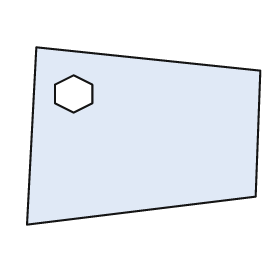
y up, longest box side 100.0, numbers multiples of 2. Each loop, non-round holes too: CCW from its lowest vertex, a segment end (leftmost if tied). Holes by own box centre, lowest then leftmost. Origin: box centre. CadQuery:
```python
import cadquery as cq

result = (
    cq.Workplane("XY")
    .moveTo(-50.0, -38.0)
    .lineTo(48.0, -26.0)
    .lineTo(50.0, 28.0)
    .lineTo(-46.0, 38.0)
    .close()
    .moveTo(-30.0, 10.0)
    .lineTo(-22.0, 14.0)
    .lineTo(-22.0, 22.0)
    .lineTo(-30.0, 26.0)
    .lineTo(-38.0, 22.0)
    .lineTo(-38.0, 14.0)
    .close()
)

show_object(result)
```